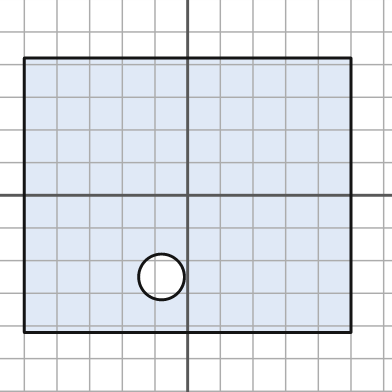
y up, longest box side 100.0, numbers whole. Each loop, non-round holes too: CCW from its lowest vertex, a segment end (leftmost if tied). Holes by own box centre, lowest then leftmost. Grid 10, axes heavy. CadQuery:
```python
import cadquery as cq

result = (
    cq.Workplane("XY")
    .moveTo(-50.0, -42.0)
    .lineTo(50.0, -42.0)
    .lineTo(50.0, 42.0)
    .lineTo(-50.0, 42.0)
    .close()
    .moveTo(-8.0, -25.0)
    .circle(7.0)
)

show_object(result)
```